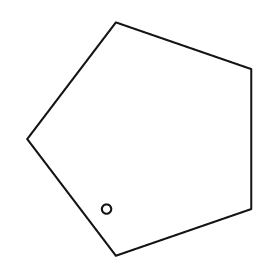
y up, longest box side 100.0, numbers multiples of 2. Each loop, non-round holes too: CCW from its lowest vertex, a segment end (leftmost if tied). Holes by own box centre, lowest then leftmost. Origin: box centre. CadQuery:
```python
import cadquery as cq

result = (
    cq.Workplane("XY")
    .moveTo(-10.0, -50.0)
    .lineTo(48.0, -30.0)
    .lineTo(48.0, 30.0)
    .lineTo(-10.0, 50.0)
    .lineTo(-48.0, 0.0)
    .close()
    .moveTo(-14.0, -30.0)
    .circle(2.0)
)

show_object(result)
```